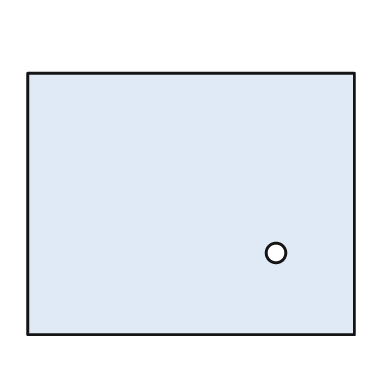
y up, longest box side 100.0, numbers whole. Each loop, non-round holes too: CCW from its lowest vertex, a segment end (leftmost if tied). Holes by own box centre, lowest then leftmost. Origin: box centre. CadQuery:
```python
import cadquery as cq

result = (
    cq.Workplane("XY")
    .moveTo(-50.0, -40.0)
    .lineTo(50.0, -40.0)
    .lineTo(50.0, 40.0)
    .lineTo(-50.0, 40.0)
    .close()
    .moveTo(26.0, -15.0)
    .circle(3.0)
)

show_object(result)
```